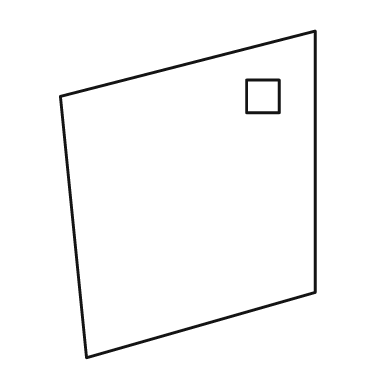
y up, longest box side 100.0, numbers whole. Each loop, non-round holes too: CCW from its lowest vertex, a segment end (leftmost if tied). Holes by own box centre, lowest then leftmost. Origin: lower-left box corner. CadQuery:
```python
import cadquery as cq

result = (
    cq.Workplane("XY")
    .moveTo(8.0, 0.0)
    .lineTo(78.0, 20.0)
    .lineTo(78.0, 100.0)
    .lineTo(0.0, 80.0)
    .close()
    .moveTo(57.0, 75.0)
    .lineTo(67.0, 75.0)
    .lineTo(67.0, 85.0)
    .lineTo(57.0, 85.0)
    .close()
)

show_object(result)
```